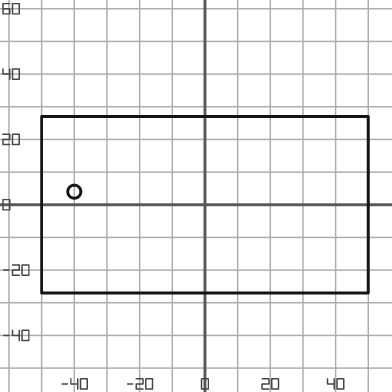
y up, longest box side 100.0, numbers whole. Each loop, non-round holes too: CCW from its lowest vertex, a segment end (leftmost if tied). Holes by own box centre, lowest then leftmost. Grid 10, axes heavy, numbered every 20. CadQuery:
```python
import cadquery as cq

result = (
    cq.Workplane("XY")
    .moveTo(-50.0, -27.0)
    .lineTo(50.0, -27.0)
    .lineTo(50.0, 27.0)
    .lineTo(-50.0, 27.0)
    .close()
    .moveTo(-40.0, 4.0)
    .circle(2.0)
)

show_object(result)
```